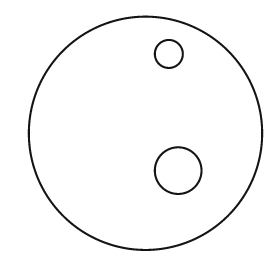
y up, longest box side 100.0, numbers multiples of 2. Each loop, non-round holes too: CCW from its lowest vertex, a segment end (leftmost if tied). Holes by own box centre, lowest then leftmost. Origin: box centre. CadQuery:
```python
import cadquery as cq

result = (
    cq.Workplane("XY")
    .moveTo(0.0, 0.0)
    .circle(50.0)
    .moveTo(14.0, -16.0)
    .circle(10.0)
    .moveTo(10.0, 34.0)
    .circle(6.0)
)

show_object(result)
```